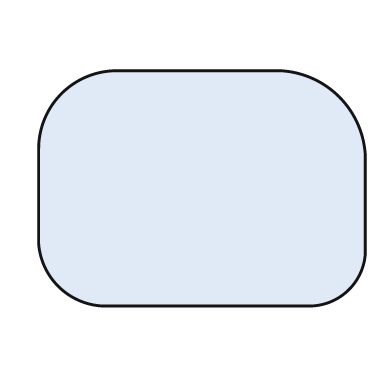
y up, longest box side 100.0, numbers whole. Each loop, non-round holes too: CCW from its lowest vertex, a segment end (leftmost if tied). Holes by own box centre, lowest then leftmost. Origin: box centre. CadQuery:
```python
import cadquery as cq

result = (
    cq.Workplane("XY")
    .moveTo(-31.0, -36.0)
    .lineTo(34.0, -36.0)
    .threePointArc((45.0, -31.0), (50.0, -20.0))
    .lineTo(50.0, 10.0)
    .threePointArc((42.0, 28.0), (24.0, 36.0))
    .lineTo(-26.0, 36.0)
    .threePointArc((-43.0, 29.0), (-50.0, 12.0))
    .lineTo(-50.0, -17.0)
    .threePointArc((-44.0, -30.0), (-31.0, -36.0))
    .close()
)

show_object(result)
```